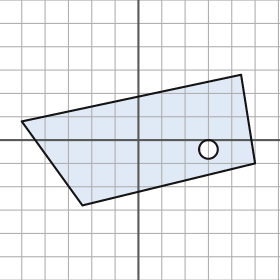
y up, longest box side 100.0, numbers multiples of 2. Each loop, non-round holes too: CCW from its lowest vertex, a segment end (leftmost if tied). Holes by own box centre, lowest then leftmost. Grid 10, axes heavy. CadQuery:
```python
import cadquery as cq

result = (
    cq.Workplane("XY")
    .moveTo(-24.0, -28.0)
    .lineTo(50.0, -10.0)
    .lineTo(44.0, 28.0)
    .lineTo(-50.0, 8.0)
    .close()
    .moveTo(30.0, -4.0)
    .circle(4.0)
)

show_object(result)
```